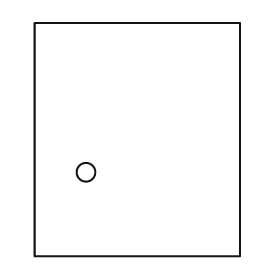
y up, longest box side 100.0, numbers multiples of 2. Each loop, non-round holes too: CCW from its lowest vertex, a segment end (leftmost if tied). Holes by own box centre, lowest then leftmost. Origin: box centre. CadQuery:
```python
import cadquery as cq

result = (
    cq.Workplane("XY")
    .moveTo(-44.0, -50.0)
    .lineTo(44.0, -50.0)
    .lineTo(44.0, 50.0)
    .lineTo(-44.0, 50.0)
    .close()
    .moveTo(-22.0, -14.0)
    .circle(4.0)
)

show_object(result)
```